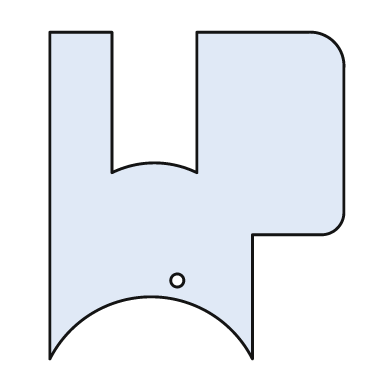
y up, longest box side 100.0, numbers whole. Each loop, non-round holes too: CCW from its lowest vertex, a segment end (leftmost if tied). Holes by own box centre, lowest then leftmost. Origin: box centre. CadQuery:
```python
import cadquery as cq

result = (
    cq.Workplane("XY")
    .moveTo(-45.0, -50.0)
    .threePointArc((-14.0, -31.0), (17.0, -50.0))
    .lineTo(17.0, -12.0)
    .lineTo(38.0, -12.0)
    .threePointArc((43.0, -10.0), (45.0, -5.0))
    .lineTo(45.0, 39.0)
    .threePointArc((42.0, 47.0), (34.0, 50.0))
    .lineTo(0.0, 50.0)
    .lineTo(0.0, 7.0)
    .threePointArc((-13.0, 10.0), (-26.0, 7.0))
    .lineTo(-26.0, 50.0)
    .lineTo(-45.0, 50.0)
    .close()
    .moveTo(-6.0, -26.0)
    .circle(2.0)
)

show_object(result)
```